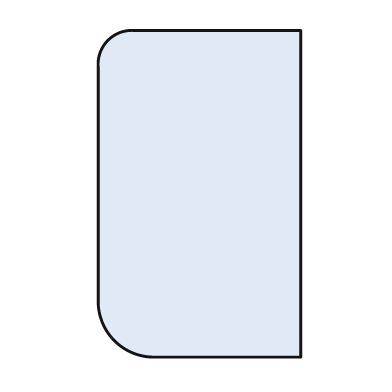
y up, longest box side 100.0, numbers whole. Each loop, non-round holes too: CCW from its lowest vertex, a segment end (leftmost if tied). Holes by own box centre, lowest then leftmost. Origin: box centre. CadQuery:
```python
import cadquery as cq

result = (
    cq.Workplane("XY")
    .moveTo(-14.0, -50.0)
    .lineTo(31.0, -50.0)
    .lineTo(31.0, 50.0)
    .lineTo(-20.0, 50.0)
    .threePointArc((-28.0, 47.0), (-31.0, 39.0))
    .lineTo(-31.0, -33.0)
    .threePointArc((-26.0, -45.0), (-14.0, -50.0))
    .close()
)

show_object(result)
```